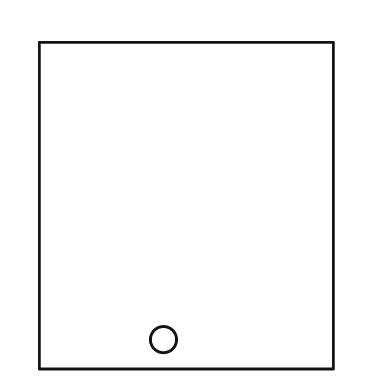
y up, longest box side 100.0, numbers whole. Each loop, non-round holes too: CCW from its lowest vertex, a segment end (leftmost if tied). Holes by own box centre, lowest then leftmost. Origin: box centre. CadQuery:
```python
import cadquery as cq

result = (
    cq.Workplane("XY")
    .moveTo(-45.0, -50.0)
    .lineTo(45.0, -50.0)
    .lineTo(45.0, 50.0)
    .lineTo(-45.0, 50.0)
    .close()
    .moveTo(-7.0, -41.0)
    .circle(4.0)
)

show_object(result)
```